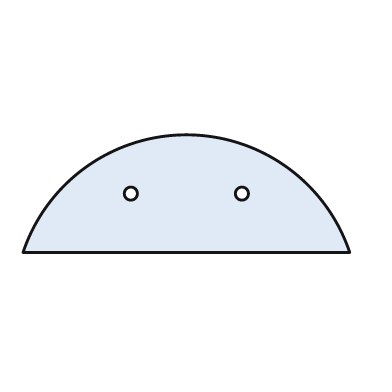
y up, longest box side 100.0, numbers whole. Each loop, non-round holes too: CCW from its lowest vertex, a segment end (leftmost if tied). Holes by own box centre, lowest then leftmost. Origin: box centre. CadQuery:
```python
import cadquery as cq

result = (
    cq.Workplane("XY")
    .moveTo(-50.0, -18.0)
    .lineTo(50.0, -18.0)
    .threePointArc((0.0, 18.0), (-50.0, -18.0))
    .close()
    .moveTo(-17.0, 0.0)
    .circle(2.0)
    .moveTo(17.0, 0.0)
    .circle(2.0)
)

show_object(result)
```